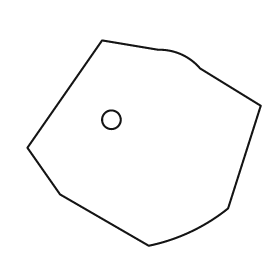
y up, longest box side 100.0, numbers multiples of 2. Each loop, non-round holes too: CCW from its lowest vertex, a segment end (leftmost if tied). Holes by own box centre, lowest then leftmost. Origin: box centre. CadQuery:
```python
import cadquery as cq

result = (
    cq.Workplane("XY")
    .moveTo(2.0, -44.0)
    .threePointArc((20.0, -38.0), (36.0, -28.0))
    .lineTo(50.0, 16.0)
    .lineTo(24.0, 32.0)
    .threePointArc((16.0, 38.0), (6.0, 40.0))
    .lineTo(-18.0, 44.0)
    .lineTo(-50.0, -2.0)
    .lineTo(-36.0, -22.0)
    .close()
    .moveTo(-14.0, 10.0)
    .circle(4.0)
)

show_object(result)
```